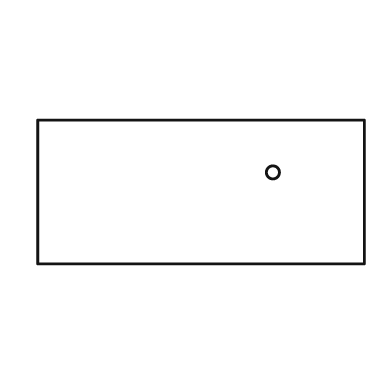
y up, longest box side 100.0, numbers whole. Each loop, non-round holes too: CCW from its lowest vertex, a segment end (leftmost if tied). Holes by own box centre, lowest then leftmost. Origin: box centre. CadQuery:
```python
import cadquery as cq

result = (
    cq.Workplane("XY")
    .moveTo(-50.0, -22.0)
    .lineTo(50.0, -22.0)
    .lineTo(50.0, 22.0)
    .lineTo(-50.0, 22.0)
    .close()
    .moveTo(22.0, 6.0)
    .circle(2.0)
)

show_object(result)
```